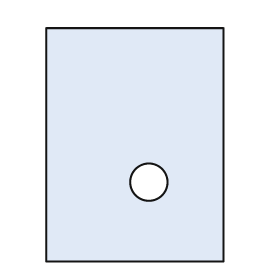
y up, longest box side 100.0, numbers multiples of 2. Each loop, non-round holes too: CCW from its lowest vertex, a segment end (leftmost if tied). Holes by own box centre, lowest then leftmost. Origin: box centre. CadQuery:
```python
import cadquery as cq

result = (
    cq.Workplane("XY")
    .moveTo(-38.0, -50.0)
    .lineTo(38.0, -50.0)
    .lineTo(38.0, 50.0)
    .lineTo(-38.0, 50.0)
    .close()
    .moveTo(6.0, -16.0)
    .circle(8.0)
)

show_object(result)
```